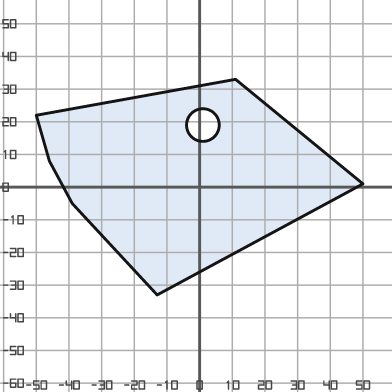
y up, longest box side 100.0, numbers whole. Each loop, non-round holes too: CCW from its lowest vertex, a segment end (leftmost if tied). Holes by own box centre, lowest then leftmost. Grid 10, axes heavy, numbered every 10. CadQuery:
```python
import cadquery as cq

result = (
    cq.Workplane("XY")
    .moveTo(-13.0, -33.0)
    .lineTo(50.0, 1.0)
    .lineTo(11.0, 33.0)
    .lineTo(-50.0, 22.0)
    .lineTo(-46.0, 8.0)
    .lineTo(-39.0, -5.0)
    .close()
    .moveTo(1.0, 19.0)
    .circle(5.0)
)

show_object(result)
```